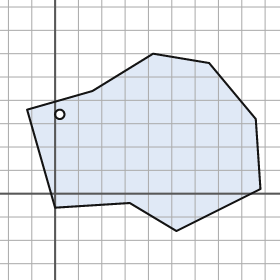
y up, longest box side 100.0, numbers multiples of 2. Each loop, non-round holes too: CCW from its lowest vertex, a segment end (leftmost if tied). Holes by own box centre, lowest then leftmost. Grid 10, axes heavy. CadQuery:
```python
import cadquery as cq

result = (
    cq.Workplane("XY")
    .moveTo(52.0, -16.0)
    .lineTo(88.0, 2.0)
    .lineTo(86.0, 32.0)
    .lineTo(66.0, 56.0)
    .lineTo(42.0, 60.0)
    .lineTo(16.0, 44.0)
    .lineTo(-12.0, 36.0)
    .lineTo(0.0, -6.0)
    .lineTo(32.0, -4.0)
    .close()
    .moveTo(2.0, 34.0)
    .circle(2.0)
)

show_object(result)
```